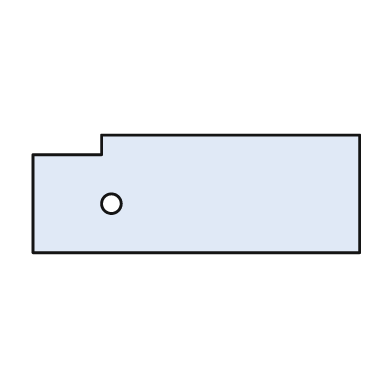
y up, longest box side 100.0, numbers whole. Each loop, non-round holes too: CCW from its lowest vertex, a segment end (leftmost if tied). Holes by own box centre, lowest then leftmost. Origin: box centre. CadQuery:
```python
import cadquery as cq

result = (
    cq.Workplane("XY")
    .moveTo(-50.0, -18.0)
    .lineTo(50.0, -18.0)
    .lineTo(50.0, 18.0)
    .lineTo(-29.0, 18.0)
    .lineTo(-29.0, 12.0)
    .lineTo(-50.0, 12.0)
    .close()
    .moveTo(-26.0, -3.0)
    .circle(3.0)
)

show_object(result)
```